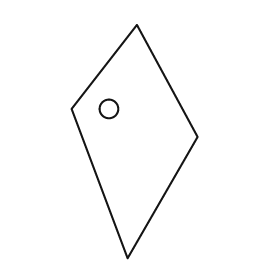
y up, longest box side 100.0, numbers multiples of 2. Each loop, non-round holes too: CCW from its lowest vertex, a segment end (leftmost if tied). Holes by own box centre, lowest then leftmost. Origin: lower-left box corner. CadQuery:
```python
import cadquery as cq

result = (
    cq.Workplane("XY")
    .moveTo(24.0, 0.0)
    .lineTo(54.0, 52.0)
    .lineTo(28.0, 100.0)
    .lineTo(0.0, 64.0)
    .close()
    .moveTo(16.0, 64.0)
    .circle(4.0)
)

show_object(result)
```